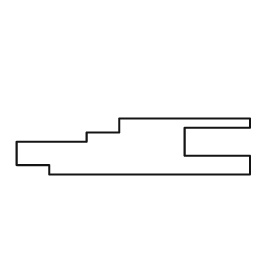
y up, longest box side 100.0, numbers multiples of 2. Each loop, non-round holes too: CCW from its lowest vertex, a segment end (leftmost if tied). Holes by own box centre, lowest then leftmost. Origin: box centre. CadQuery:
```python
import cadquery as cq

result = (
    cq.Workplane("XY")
    .moveTo(-36.0, -12.0)
    .lineTo(50.0, -12.0)
    .lineTo(50.0, -4.0)
    .lineTo(22.0, -4.0)
    .lineTo(22.0, 8.0)
    .lineTo(50.0, 8.0)
    .lineTo(50.0, 12.0)
    .lineTo(-6.0, 12.0)
    .lineTo(-6.0, 6.0)
    .lineTo(-20.0, 6.0)
    .lineTo(-20.0, 2.0)
    .lineTo(-50.0, 2.0)
    .lineTo(-50.0, -8.0)
    .lineTo(-36.0, -8.0)
    .close()
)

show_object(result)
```